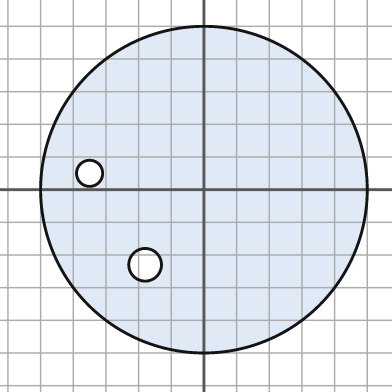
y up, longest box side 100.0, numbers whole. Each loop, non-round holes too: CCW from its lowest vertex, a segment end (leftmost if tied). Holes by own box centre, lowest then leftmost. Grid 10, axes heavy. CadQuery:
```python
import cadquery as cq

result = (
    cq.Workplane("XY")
    .moveTo(0.0, 0.0)
    .circle(50.0)
    .moveTo(-18.0, -23.0)
    .circle(5.0)
    .moveTo(-35.0, 5.0)
    .circle(4.0)
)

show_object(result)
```